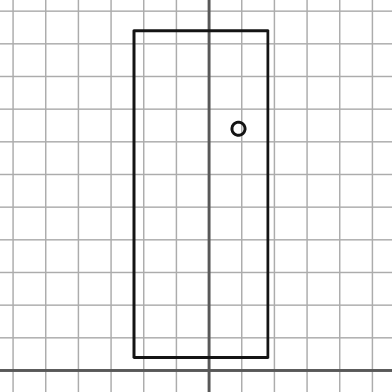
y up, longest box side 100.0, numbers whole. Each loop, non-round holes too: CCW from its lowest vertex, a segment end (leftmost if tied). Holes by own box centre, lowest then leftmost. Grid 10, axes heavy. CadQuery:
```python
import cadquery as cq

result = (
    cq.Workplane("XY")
    .moveTo(-23.0, 4.0)
    .lineTo(18.0, 4.0)
    .lineTo(18.0, 104.0)
    .lineTo(-23.0, 104.0)
    .close()
    .moveTo(9.0, 74.0)
    .circle(2.0)
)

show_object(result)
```